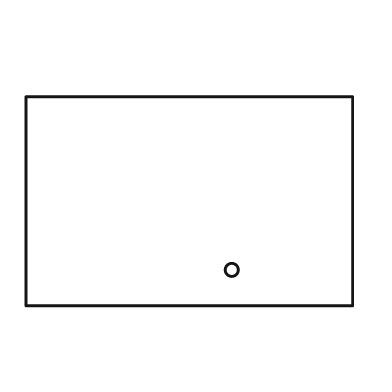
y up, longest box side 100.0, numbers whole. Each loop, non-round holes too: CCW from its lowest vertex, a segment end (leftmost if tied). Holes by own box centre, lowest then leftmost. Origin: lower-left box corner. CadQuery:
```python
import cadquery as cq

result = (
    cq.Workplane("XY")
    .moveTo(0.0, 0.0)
    .lineTo(100.0, 0.0)
    .lineTo(100.0, 64.0)
    .lineTo(0.0, 64.0)
    .close()
    .moveTo(63.0, 11.0)
    .circle(2.0)
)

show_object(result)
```